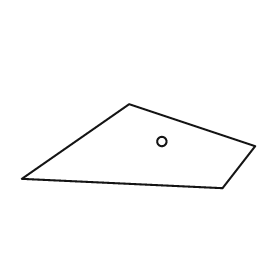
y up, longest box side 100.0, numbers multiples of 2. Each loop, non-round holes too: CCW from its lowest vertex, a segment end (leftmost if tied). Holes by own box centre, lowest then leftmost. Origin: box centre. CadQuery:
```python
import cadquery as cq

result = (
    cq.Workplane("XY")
    .moveTo(36.0, -18.0)
    .lineTo(50.0, 0.0)
    .lineTo(-4.0, 18.0)
    .lineTo(-50.0, -14.0)
    .close()
    .moveTo(10.0, 2.0)
    .circle(2.0)
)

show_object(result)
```